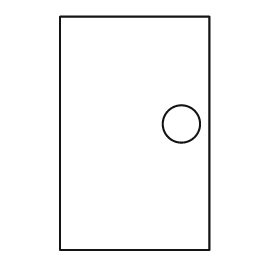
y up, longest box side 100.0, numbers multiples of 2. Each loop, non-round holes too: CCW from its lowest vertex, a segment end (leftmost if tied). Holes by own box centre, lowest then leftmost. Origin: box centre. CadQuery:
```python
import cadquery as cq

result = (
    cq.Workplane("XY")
    .moveTo(-32.0, -50.0)
    .lineTo(32.0, -50.0)
    .lineTo(32.0, 50.0)
    .lineTo(-32.0, 50.0)
    .close()
    .moveTo(20.0, 4.0)
    .circle(8.0)
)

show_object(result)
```